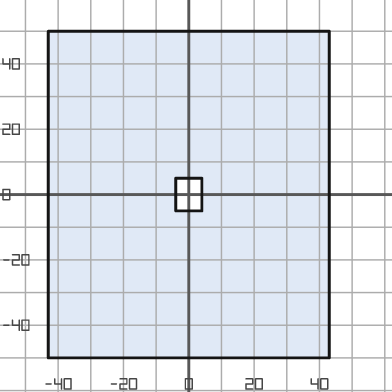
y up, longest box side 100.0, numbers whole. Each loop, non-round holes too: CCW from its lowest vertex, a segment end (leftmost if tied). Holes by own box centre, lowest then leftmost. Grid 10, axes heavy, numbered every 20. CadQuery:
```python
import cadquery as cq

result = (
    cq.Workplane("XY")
    .moveTo(-43.0, -50.0)
    .lineTo(43.0, -50.0)
    .lineTo(43.0, 50.0)
    .lineTo(-43.0, 50.0)
    .close()
    .moveTo(-4.0, -5.0)
    .lineTo(4.0, -5.0)
    .lineTo(4.0, 5.0)
    .lineTo(-4.0, 5.0)
    .close()
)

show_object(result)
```